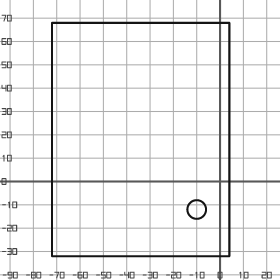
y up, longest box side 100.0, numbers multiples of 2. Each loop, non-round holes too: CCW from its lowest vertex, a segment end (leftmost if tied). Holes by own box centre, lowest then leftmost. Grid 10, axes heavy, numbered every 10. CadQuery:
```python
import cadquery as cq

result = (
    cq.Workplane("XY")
    .moveTo(-72.0, -32.0)
    .lineTo(4.0, -32.0)
    .lineTo(4.0, 68.0)
    .lineTo(-72.0, 68.0)
    .close()
    .moveTo(-10.0, -12.0)
    .circle(4.0)
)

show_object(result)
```